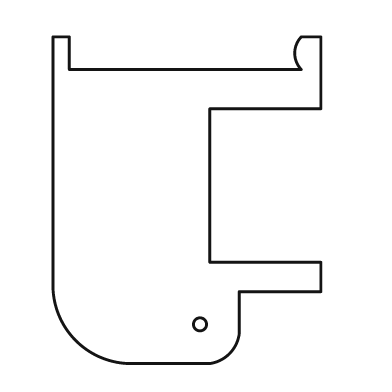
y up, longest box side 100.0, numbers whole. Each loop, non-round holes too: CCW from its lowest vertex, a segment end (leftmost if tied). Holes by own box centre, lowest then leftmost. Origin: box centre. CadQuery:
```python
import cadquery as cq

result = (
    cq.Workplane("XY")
    .moveTo(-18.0, -50.0)
    .lineTo(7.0, -50.0)
    .threePointArc((13.0, -47.0), (16.0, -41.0))
    .lineTo(16.0, -28.0)
    .lineTo(41.0, -28.0)
    .lineTo(41.0, -19.0)
    .lineTo(7.0, -19.0)
    .lineTo(7.0, 28.0)
    .lineTo(41.0, 28.0)
    .lineTo(41.0, 50.0)
    .lineTo(35.0, 50.0)
    .threePointArc((33.0, 45.0), (35.0, 40.0))
    .lineTo(-36.0, 40.0)
    .lineTo(-36.0, 50.0)
    .lineTo(-41.0, 50.0)
    .lineTo(-41.0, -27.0)
    .threePointArc((-34.0, -43.0), (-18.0, -50.0))
    .close()
    .moveTo(4.0, -38.0)
    .circle(2.0)
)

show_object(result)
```